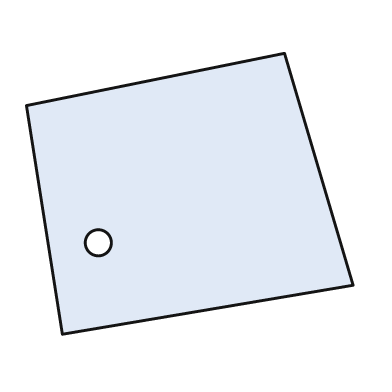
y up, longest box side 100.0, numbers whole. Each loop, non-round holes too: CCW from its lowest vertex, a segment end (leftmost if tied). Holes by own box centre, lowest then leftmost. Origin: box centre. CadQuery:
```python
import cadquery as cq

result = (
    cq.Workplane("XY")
    .moveTo(-39.0, -43.0)
    .lineTo(50.0, -28.0)
    .lineTo(29.0, 43.0)
    .lineTo(-50.0, 27.0)
    .close()
    .moveTo(-28.0, -15.0)
    .circle(4.0)
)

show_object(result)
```